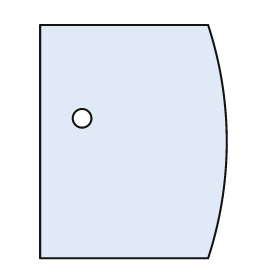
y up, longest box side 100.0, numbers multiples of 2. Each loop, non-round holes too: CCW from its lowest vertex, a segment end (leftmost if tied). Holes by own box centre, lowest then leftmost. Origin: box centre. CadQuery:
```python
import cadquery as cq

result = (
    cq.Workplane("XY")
    .moveTo(-40.0, -50.0)
    .lineTo(32.0, -50.0)
    .threePointArc((40.0, 0.0), (32.0, 50.0))
    .lineTo(-40.0, 50.0)
    .close()
    .moveTo(-22.0, 10.0)
    .circle(4.0)
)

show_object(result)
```